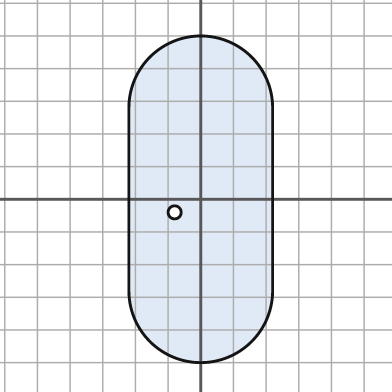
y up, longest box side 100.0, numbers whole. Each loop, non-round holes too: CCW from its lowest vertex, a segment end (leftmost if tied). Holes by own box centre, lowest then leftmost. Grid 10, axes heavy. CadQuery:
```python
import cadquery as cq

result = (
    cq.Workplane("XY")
    .moveTo(-22.0, -28.0)
    .threePointArc((0.0, -50.0), (22.0, -28.0))
    .lineTo(22.0, 28.0)
    .threePointArc((0.0, 50.0), (-22.0, 28.0))
    .close()
    .moveTo(-8.0, -4.0)
    .circle(2.0)
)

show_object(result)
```